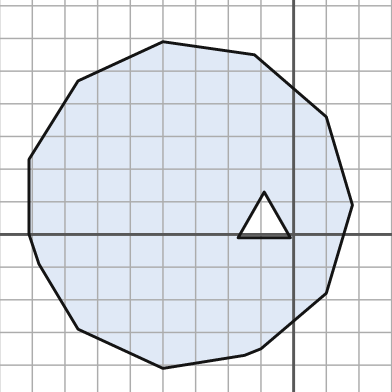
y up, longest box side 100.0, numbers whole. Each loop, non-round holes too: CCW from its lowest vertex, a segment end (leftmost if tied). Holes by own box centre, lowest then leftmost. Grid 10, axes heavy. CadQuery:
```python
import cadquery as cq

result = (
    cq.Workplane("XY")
    .moveTo(-40.0, -41.0)
    .lineTo(-15.0, -37.0)
    .lineTo(-10.0, -35.0)
    .lineTo(10.0, -18.0)
    .lineTo(18.0, 9.0)
    .lineTo(10.0, 36.0)
    .lineTo(-12.0, 55.0)
    .lineTo(-40.0, 59.0)
    .lineTo(-66.0, 47.0)
    .lineTo(-81.0, 23.0)
    .lineTo(-81.0, 0.0)
    .lineTo(-78.0, -9.0)
    .lineTo(-66.0, -29.0)
    .close()
    .moveTo(-17.0, -1.0)
    .lineTo(-1.0, -1.0)
    .lineTo(-9.0, 13.0)
    .close()
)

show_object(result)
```